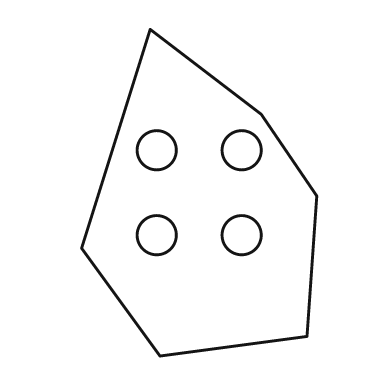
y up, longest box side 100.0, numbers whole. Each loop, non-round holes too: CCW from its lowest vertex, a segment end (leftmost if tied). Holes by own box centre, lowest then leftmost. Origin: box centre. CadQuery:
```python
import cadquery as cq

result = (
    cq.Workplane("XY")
    .moveTo(-12.0, -50.0)
    .lineTo(33.0, -44.0)
    .lineTo(36.0, -1.0)
    .lineTo(19.0, 24.0)
    .lineTo(-15.0, 50.0)
    .lineTo(-36.0, -17.0)
    .close()
    .moveTo(-13.0, -13.0)
    .circle(6.0)
    .moveTo(13.0, -13.0)
    .circle(6.0)
    .moveTo(-13.0, 13.0)
    .circle(6.0)
    .moveTo(13.0, 13.0)
    .circle(6.0)
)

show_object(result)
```